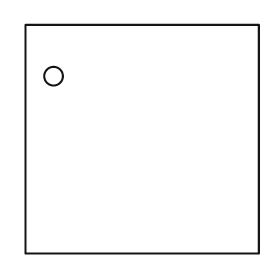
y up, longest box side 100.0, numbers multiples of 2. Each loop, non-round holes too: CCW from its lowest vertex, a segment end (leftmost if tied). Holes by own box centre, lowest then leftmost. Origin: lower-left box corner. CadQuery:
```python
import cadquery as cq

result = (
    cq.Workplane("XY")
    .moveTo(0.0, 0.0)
    .lineTo(100.0, 0.0)
    .lineTo(100.0, 98.0)
    .lineTo(0.0, 98.0)
    .close()
    .moveTo(12.0, 76.0)
    .circle(4.0)
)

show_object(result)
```